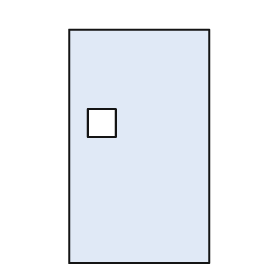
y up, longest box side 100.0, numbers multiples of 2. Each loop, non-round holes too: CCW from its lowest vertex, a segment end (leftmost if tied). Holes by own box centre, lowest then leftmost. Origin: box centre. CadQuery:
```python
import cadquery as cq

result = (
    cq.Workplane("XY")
    .moveTo(-30.0, -50.0)
    .lineTo(30.0, -50.0)
    .lineTo(30.0, 50.0)
    .lineTo(-30.0, 50.0)
    .close()
    .moveTo(-22.0, 4.0)
    .lineTo(-10.0, 4.0)
    .lineTo(-10.0, 16.0)
    .lineTo(-22.0, 16.0)
    .close()
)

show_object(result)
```